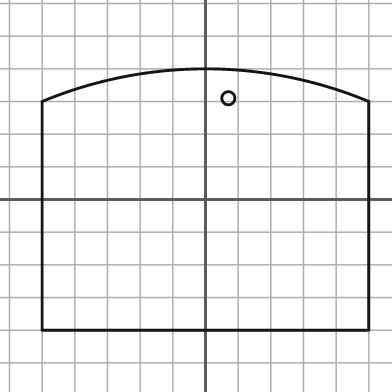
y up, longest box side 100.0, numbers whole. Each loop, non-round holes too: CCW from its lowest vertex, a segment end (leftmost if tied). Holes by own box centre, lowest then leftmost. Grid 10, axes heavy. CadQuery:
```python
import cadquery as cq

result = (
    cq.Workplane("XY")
    .moveTo(-50.0, -40.0)
    .lineTo(50.0, -40.0)
    .lineTo(50.0, 30.0)
    .threePointArc((0.0, 40.0), (-50.0, 30.0))
    .close()
    .moveTo(7.0, 31.0)
    .circle(2.0)
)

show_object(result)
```